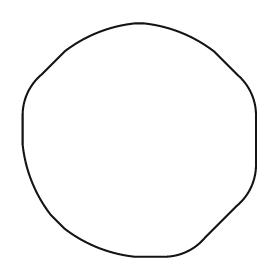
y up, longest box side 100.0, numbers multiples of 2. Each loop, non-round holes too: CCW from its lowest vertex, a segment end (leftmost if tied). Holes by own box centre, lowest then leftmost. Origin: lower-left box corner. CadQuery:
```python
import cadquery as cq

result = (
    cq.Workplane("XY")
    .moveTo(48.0, 0.0)
    .lineTo(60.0, 0.0)
    .threePointArc((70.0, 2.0), (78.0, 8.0))
    .lineTo(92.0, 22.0)
    .threePointArc((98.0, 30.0), (100.0, 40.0))
    .lineTo(100.0, 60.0)
    .threePointArc((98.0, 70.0), (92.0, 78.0))
    .lineTo(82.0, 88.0)
    .threePointArc((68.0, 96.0), (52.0, 100.0))
    .lineTo(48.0, 100.0)
    .threePointArc((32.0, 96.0), (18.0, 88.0))
    .lineTo(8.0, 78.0)
    .threePointArc((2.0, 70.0), (0.0, 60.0))
    .lineTo(0.0, 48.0)
    .threePointArc((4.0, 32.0), (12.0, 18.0))
    .lineTo(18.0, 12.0)
    .threePointArc((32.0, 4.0), (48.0, 0.0))
    .close()
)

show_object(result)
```